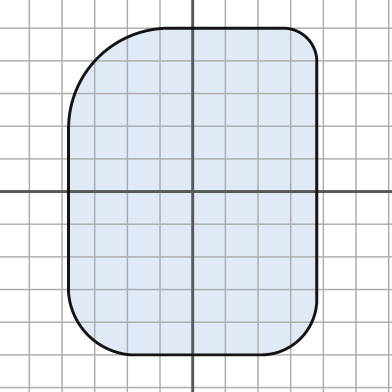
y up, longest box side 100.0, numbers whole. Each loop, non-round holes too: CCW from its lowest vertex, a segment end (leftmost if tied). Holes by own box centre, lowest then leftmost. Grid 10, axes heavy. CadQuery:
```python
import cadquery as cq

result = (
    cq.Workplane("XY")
    .moveTo(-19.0, -50.0)
    .lineTo(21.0, -50.0)
    .threePointArc((33.0, -45.0), (38.0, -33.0))
    .lineTo(38.0, 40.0)
    .threePointArc((35.0, 47.0), (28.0, 50.0))
    .lineTo(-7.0, 50.0)
    .threePointArc((-29.0, 41.0), (-38.0, 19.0))
    .lineTo(-38.0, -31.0)
    .threePointArc((-32.0, -44.0), (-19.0, -50.0))
    .close()
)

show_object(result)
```